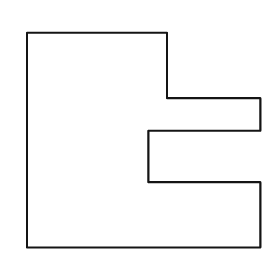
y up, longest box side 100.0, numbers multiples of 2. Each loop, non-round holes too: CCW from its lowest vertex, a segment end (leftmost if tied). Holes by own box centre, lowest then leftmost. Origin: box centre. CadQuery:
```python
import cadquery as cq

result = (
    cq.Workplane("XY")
    .moveTo(-50.0, -46.0)
    .lineTo(50.0, -46.0)
    .lineTo(50.0, -18.0)
    .lineTo(2.0, -18.0)
    .lineTo(2.0, 4.0)
    .lineTo(50.0, 4.0)
    .lineTo(50.0, 18.0)
    .lineTo(10.0, 18.0)
    .lineTo(10.0, 46.0)
    .lineTo(-50.0, 46.0)
    .close()
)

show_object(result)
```